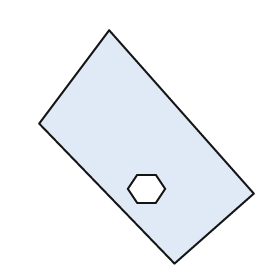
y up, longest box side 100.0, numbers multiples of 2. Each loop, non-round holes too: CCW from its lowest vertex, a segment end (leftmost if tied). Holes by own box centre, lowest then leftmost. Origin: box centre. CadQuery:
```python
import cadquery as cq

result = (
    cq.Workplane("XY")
    .moveTo(12.0, -50.0)
    .lineTo(46.0, -20.0)
    .lineTo(-16.0, 50.0)
    .lineTo(-46.0, 10.0)
    .close()
    .moveTo(-4.0, -24.0)
    .lineTo(4.0, -24.0)
    .lineTo(8.0, -18.0)
    .lineTo(4.0, -12.0)
    .lineTo(-4.0, -12.0)
    .lineTo(-8.0, -18.0)
    .close()
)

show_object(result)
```